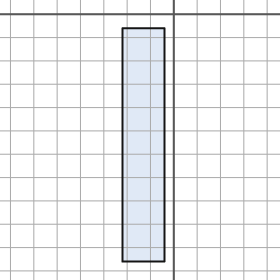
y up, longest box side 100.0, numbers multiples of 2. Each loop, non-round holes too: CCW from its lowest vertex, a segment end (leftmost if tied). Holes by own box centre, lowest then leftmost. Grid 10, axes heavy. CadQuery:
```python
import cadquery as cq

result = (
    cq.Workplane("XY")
    .moveTo(-22.0, -106.0)
    .lineTo(-4.0, -106.0)
    .lineTo(-4.0, -6.0)
    .lineTo(-22.0, -6.0)
    .close()
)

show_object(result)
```